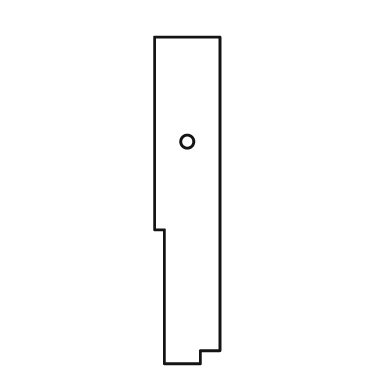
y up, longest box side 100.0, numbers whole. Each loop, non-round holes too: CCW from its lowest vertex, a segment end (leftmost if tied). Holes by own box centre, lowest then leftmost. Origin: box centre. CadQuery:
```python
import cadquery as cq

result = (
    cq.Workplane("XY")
    .moveTo(-7.0, -50.0)
    .lineTo(4.0, -50.0)
    .lineTo(4.0, -46.0)
    .lineTo(10.0, -46.0)
    .lineTo(10.0, 50.0)
    .lineTo(-10.0, 50.0)
    .lineTo(-10.0, -9.0)
    .lineTo(-7.0, -9.0)
    .close()
    .moveTo(0.0, 18.0)
    .circle(2.0)
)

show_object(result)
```